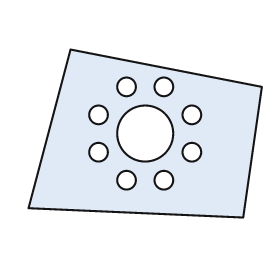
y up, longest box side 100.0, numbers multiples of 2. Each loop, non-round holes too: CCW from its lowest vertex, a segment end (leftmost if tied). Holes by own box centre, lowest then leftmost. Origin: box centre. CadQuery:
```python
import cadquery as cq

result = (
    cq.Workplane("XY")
    .moveTo(42.0, -36.0)
    .lineTo(50.0, 20.0)
    .lineTo(-32.0, 36.0)
    .lineTo(-50.0, -32.0)
    .close()
    .moveTo(-8.0, -20.0)
    .circle(4.0)
    .moveTo(8.0, -20.0)
    .circle(4.0)
    .moveTo(-20.0, -8.0)
    .circle(4.0)
    .moveTo(20.0, -8.0)
    .circle(4.0)
    .moveTo(0.0, 0.0)
    .circle(12.0)
    .moveTo(-20.0, 8.0)
    .circle(4.0)
    .moveTo(20.0, 8.0)
    .circle(4.0)
    .moveTo(-8.0, 20.0)
    .circle(4.0)
    .moveTo(8.0, 20.0)
    .circle(4.0)
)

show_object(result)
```